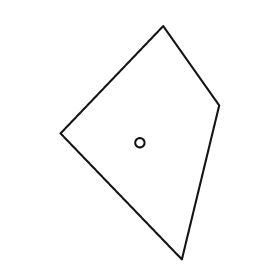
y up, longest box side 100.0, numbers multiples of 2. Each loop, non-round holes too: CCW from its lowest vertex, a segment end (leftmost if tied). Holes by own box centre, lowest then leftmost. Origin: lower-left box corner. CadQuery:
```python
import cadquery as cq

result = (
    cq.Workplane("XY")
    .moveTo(52.0, 0.0)
    .lineTo(68.0, 66.0)
    .lineTo(44.0, 100.0)
    .lineTo(0.0, 54.0)
    .close()
    .moveTo(34.0, 50.0)
    .circle(2.0)
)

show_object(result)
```